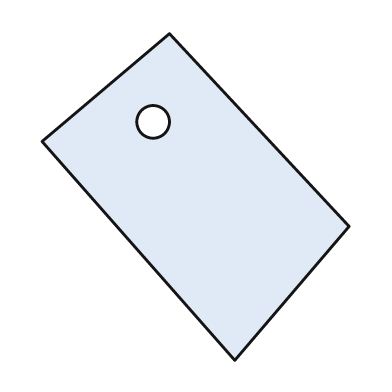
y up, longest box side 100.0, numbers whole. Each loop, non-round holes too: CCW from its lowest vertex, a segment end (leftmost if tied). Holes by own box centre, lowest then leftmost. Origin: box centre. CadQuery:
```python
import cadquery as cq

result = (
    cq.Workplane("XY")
    .moveTo(12.0, -50.0)
    .lineTo(47.0, -9.0)
    .lineTo(-8.0, 50.0)
    .lineTo(-47.0, 17.0)
    .close()
    .moveTo(-13.0, 23.0)
    .circle(5.0)
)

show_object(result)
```